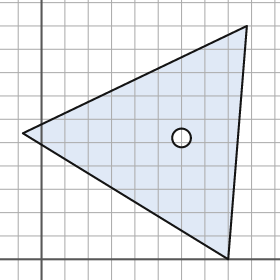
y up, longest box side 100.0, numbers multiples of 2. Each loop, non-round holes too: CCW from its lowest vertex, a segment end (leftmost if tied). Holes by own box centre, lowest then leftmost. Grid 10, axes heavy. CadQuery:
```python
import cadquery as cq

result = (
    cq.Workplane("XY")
    .moveTo(80.0, 0.0)
    .lineTo(88.0, 100.0)
    .lineTo(-8.0, 54.0)
    .close()
    .moveTo(60.0, 52.0)
    .circle(4.0)
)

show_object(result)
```